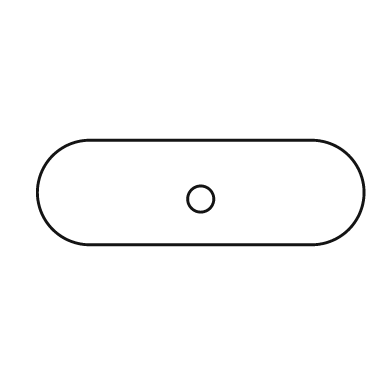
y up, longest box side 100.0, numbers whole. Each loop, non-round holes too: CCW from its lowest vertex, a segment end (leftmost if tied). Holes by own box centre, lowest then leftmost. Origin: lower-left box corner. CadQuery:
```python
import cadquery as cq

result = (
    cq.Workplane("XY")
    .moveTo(16.0, 0.0)
    .lineTo(84.0, 0.0)
    .threePointArc((100.0, 16.0), (84.0, 32.0))
    .lineTo(16.0, 32.0)
    .threePointArc((0.0, 16.0), (16.0, 0.0))
    .close()
    .moveTo(50.0, 14.0)
    .circle(4.0)
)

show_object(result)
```